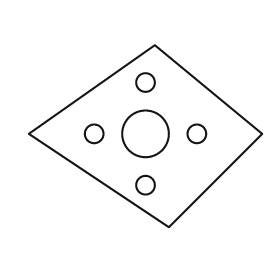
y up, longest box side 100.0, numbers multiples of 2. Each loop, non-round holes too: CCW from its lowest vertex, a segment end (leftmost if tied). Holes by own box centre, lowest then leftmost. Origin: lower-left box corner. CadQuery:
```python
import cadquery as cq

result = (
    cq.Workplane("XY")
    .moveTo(60.0, 0.0)
    .lineTo(100.0, 40.0)
    .lineTo(54.0, 78.0)
    .lineTo(0.0, 40.0)
    .close()
    .moveTo(50.0, 18.0)
    .circle(4.0)
    .moveTo(28.0, 40.0)
    .circle(4.0)
    .moveTo(50.0, 40.0)
    .circle(10.0)
    .moveTo(72.0, 40.0)
    .circle(4.0)
    .moveTo(50.0, 62.0)
    .circle(4.0)
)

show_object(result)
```